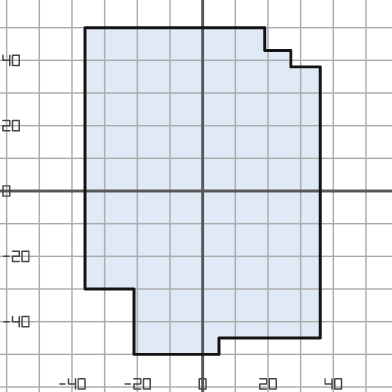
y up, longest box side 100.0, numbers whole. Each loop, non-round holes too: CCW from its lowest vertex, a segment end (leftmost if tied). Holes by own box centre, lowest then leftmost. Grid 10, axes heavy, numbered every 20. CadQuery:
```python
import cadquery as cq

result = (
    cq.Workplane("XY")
    .moveTo(-21.0, -50.0)
    .lineTo(5.0, -50.0)
    .lineTo(5.0, -45.0)
    .lineTo(36.0, -45.0)
    .lineTo(36.0, 38.0)
    .lineTo(27.0, 38.0)
    .lineTo(27.0, 43.0)
    .lineTo(19.0, 43.0)
    .lineTo(19.0, 50.0)
    .lineTo(-36.0, 50.0)
    .lineTo(-36.0, -30.0)
    .lineTo(-21.0, -30.0)
    .close()
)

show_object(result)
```